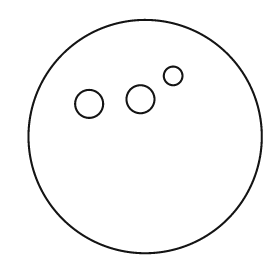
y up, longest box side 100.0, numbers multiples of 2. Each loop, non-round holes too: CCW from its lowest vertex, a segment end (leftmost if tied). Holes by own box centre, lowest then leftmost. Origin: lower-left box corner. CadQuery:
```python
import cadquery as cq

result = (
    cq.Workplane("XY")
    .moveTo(50.0, 50.0)
    .circle(50.0)
    .moveTo(26.0, 64.0)
    .circle(6.0)
    .moveTo(48.0, 66.0)
    .circle(6.0)
    .moveTo(62.0, 76.0)
    .circle(4.0)
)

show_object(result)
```